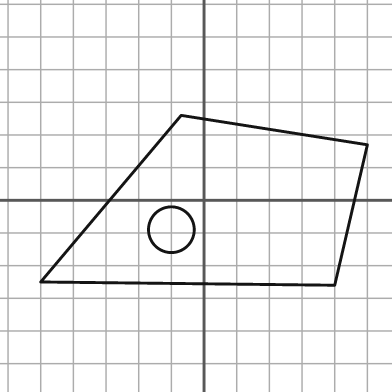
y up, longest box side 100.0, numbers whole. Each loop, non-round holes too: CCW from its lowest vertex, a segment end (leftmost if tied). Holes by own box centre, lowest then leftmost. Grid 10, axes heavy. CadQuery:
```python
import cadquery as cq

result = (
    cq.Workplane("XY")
    .moveTo(40.0, -26.0)
    .lineTo(50.0, 17.0)
    .lineTo(-7.0, 26.0)
    .lineTo(-50.0, -25.0)
    .close()
    .moveTo(-10.0, -9.0)
    .circle(7.0)
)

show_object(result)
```